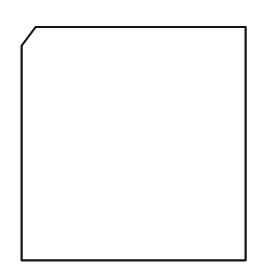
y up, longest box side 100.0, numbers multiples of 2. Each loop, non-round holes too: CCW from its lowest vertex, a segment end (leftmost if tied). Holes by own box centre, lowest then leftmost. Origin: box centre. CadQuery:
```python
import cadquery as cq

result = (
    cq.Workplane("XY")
    .moveTo(-48.0, -50.0)
    .lineTo(48.0, -50.0)
    .lineTo(48.0, 50.0)
    .lineTo(-42.0, 50.0)
    .lineTo(-48.0, 42.0)
    .close()
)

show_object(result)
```